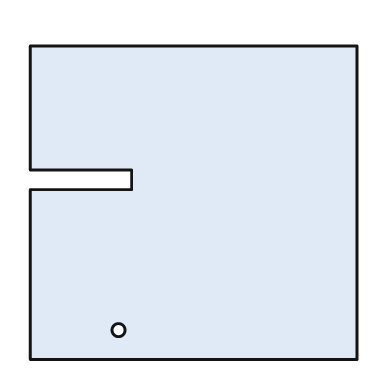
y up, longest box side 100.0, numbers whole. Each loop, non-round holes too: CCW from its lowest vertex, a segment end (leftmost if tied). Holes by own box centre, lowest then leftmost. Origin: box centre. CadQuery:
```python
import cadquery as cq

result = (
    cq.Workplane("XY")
    .moveTo(-50.0, -48.0)
    .lineTo(50.0, -48.0)
    .lineTo(50.0, 48.0)
    .lineTo(-50.0, 48.0)
    .lineTo(-50.0, 10.0)
    .lineTo(-19.0, 10.0)
    .lineTo(-19.0, 4.0)
    .lineTo(-50.0, 4.0)
    .close()
    .moveTo(-23.0, -39.0)
    .circle(2.0)
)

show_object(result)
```